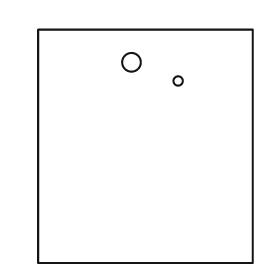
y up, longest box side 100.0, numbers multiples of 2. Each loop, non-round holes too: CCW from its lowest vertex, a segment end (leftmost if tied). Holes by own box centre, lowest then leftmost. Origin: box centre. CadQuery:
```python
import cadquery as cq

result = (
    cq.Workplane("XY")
    .moveTo(-46.0, -50.0)
    .lineTo(46.0, -50.0)
    .lineTo(46.0, 50.0)
    .lineTo(-46.0, 50.0)
    .close()
    .moveTo(14.0, 28.0)
    .circle(2.0)
    .moveTo(-6.0, 36.0)
    .circle(4.0)
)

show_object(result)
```